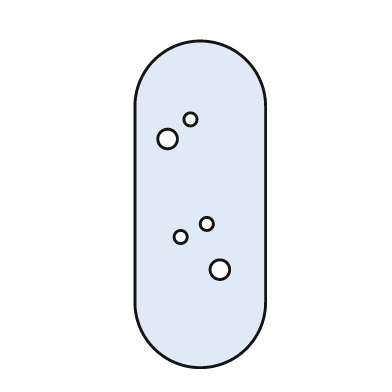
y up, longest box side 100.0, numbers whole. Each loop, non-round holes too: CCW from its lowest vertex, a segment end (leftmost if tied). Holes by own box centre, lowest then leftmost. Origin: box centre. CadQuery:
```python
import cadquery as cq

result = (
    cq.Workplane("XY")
    .moveTo(-20.0, -30.0)
    .threePointArc((0.0, -50.0), (20.0, -30.0))
    .lineTo(20.0, 30.0)
    .threePointArc((0.0, 50.0), (-20.0, 30.0))
    .close()
    .moveTo(6.0, -20.0)
    .circle(3.0)
    .moveTo(-6.0, -10.0)
    .circle(2.0)
    .moveTo(2.0, -6.0)
    .circle(2.0)
    .moveTo(-10.0, 20.0)
    .circle(3.0)
    .moveTo(-3.0, 26.0)
    .circle(2.0)
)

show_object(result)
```